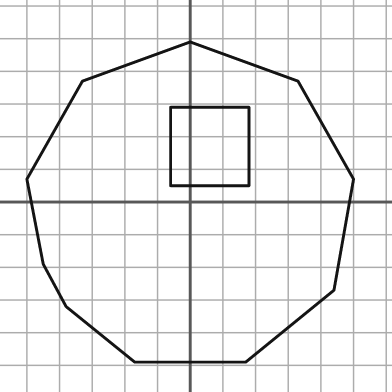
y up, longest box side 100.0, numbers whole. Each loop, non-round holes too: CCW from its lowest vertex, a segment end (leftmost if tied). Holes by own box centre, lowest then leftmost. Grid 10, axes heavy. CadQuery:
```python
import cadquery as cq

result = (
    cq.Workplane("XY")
    .moveTo(-17.0, -49.0)
    .lineTo(17.0, -49.0)
    .lineTo(44.0, -27.0)
    .lineTo(50.0, 7.0)
    .lineTo(33.0, 37.0)
    .lineTo(0.0, 49.0)
    .lineTo(-33.0, 37.0)
    .lineTo(-50.0, 7.0)
    .lineTo(-45.0, -19.0)
    .lineTo(-38.0, -32.0)
    .close()
    .moveTo(-6.0, 5.0)
    .lineTo(18.0, 5.0)
    .lineTo(18.0, 29.0)
    .lineTo(-6.0, 29.0)
    .close()
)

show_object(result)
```